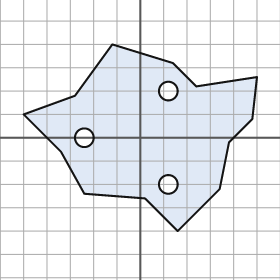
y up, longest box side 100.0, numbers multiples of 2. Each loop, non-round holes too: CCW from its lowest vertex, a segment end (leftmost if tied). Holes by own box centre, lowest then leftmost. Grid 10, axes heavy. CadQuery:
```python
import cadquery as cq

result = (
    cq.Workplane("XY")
    .moveTo(16.0, -40.0)
    .lineTo(34.0, -22.0)
    .lineTo(38.0, -2.0)
    .lineTo(48.0, 8.0)
    .lineTo(50.0, 26.0)
    .lineTo(24.0, 22.0)
    .lineTo(14.0, 32.0)
    .lineTo(-12.0, 40.0)
    .lineTo(-28.0, 18.0)
    .lineTo(-50.0, 10.0)
    .lineTo(-34.0, -6.0)
    .lineTo(-24.0, -24.0)
    .lineTo(2.0, -26.0)
    .close()
    .moveTo(12.0, -20.0)
    .circle(4.0)
    .moveTo(-24.0, 0.0)
    .circle(4.0)
    .moveTo(12.0, 20.0)
    .circle(4.0)
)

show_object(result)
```